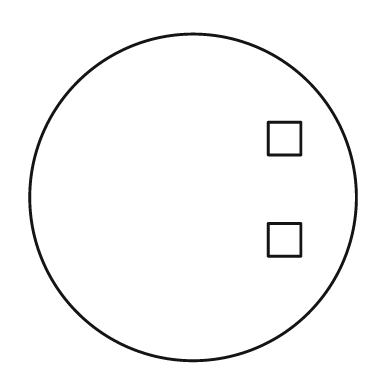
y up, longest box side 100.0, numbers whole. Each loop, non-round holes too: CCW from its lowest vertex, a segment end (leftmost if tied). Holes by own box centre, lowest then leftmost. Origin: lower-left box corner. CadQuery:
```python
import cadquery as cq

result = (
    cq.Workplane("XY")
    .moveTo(50.0, 50.0)
    .circle(50.0)
    .moveTo(73.0, 32.0)
    .lineTo(83.0, 32.0)
    .lineTo(83.0, 42.0)
    .lineTo(73.0, 42.0)
    .close()
    .moveTo(73.0, 63.0)
    .lineTo(83.0, 63.0)
    .lineTo(83.0, 73.0)
    .lineTo(73.0, 73.0)
    .close()
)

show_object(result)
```